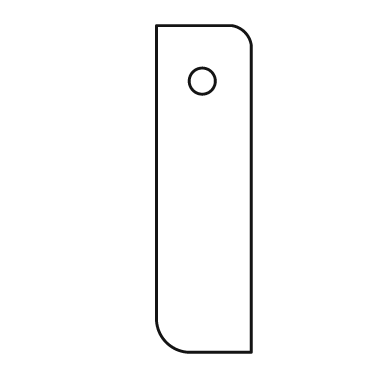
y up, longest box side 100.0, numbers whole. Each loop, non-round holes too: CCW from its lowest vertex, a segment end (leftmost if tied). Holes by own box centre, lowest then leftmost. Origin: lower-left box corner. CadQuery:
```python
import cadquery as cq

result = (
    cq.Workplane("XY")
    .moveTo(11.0, 0.0)
    .lineTo(29.0, 0.0)
    .lineTo(29.0, 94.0)
    .threePointArc((27.0, 98.0), (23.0, 100.0))
    .lineTo(0.0, 100.0)
    .lineTo(0.0, 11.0)
    .threePointArc((3.0, 3.0), (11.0, 0.0))
    .close()
    .moveTo(14.0, 83.0)
    .circle(4.0)
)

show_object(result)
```